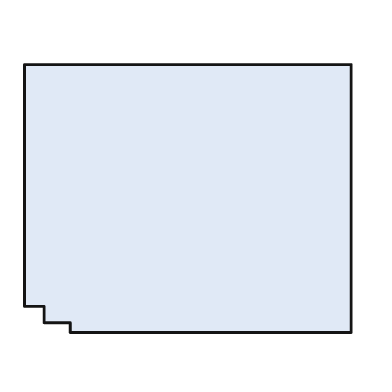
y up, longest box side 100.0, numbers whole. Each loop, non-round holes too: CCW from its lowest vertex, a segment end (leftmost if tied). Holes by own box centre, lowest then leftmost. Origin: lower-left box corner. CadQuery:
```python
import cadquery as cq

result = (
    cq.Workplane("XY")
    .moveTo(14.0, 0.0)
    .lineTo(100.0, 0.0)
    .lineTo(100.0, 82.0)
    .lineTo(0.0, 82.0)
    .lineTo(0.0, 8.0)
    .lineTo(6.0, 8.0)
    .lineTo(6.0, 3.0)
    .lineTo(14.0, 3.0)
    .close()
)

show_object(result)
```